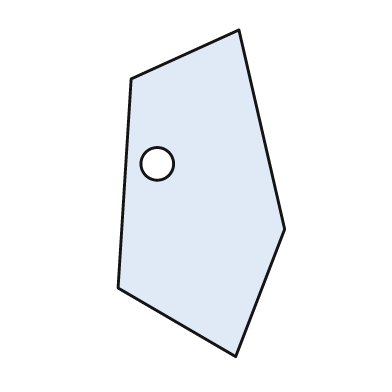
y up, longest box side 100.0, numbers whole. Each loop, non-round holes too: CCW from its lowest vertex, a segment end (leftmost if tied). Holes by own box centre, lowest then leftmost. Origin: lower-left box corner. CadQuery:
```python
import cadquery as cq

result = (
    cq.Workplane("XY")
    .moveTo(36.0, 0.0)
    .lineTo(51.0, 39.0)
    .lineTo(37.0, 100.0)
    .lineTo(4.0, 85.0)
    .lineTo(0.0, 21.0)
    .close()
    .moveTo(12.0, 59.0)
    .circle(5.0)
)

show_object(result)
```